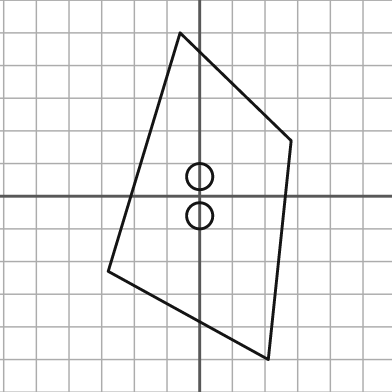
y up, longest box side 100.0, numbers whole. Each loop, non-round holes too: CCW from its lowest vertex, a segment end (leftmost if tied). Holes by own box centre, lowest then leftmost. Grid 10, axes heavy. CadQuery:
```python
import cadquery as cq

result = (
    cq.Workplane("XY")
    .moveTo(21.0, -50.0)
    .lineTo(28.0, 17.0)
    .lineTo(-6.0, 50.0)
    .lineTo(-28.0, -23.0)
    .close()
    .moveTo(0.0, -6.0)
    .circle(4.0)
    .moveTo(0.0, 6.0)
    .circle(4.0)
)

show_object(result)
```